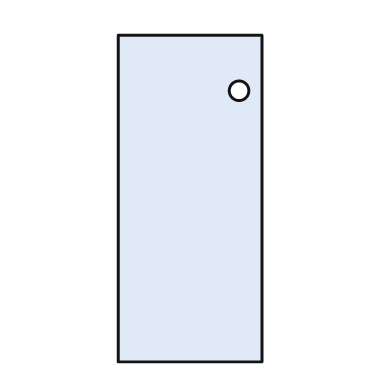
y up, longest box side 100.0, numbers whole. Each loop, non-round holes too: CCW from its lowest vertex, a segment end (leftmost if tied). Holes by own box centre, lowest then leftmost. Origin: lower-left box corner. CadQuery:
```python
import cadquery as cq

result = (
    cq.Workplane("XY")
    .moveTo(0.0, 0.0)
    .lineTo(44.0, 0.0)
    .lineTo(44.0, 100.0)
    .lineTo(0.0, 100.0)
    .close()
    .moveTo(37.0, 83.0)
    .circle(3.0)
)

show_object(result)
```